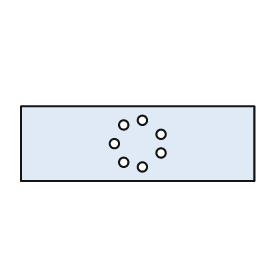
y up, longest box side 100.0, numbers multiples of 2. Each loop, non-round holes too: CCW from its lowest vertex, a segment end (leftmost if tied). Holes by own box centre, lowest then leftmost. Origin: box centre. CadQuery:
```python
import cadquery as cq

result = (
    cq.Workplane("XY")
    .moveTo(-50.0, -16.0)
    .lineTo(50.0, -16.0)
    .lineTo(50.0, 16.0)
    .lineTo(-50.0, 16.0)
    .close()
    .moveTo(2.0, -10.0)
    .circle(2.0)
    .moveTo(-6.0, -8.0)
    .circle(2.0)
    .moveTo(10.0, -4.0)
    .circle(2.0)
    .moveTo(-10.0, 0.0)
    .circle(2.0)
    .moveTo(10.0, 4.0)
    .circle(2.0)
    .moveTo(-6.0, 8.0)
    .circle(2.0)
    .moveTo(2.0, 10.0)
    .circle(2.0)
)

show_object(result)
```